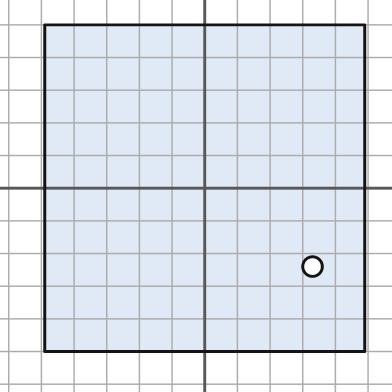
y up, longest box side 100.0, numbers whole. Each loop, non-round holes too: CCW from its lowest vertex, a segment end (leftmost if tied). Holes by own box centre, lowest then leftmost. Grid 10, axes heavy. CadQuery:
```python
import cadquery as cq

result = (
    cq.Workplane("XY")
    .moveTo(-49.0, -50.0)
    .lineTo(49.0, -50.0)
    .lineTo(49.0, 50.0)
    .lineTo(-49.0, 50.0)
    .close()
    .moveTo(33.0, -24.0)
    .circle(3.0)
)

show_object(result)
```